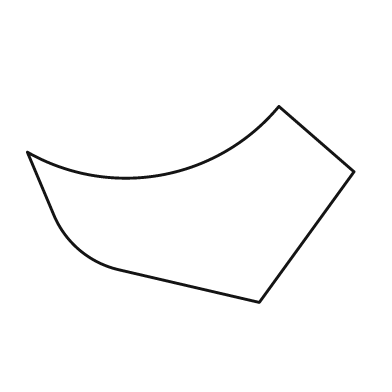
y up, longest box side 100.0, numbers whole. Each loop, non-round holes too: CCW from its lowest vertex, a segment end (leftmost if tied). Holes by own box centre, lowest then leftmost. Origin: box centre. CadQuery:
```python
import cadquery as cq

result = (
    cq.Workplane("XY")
    .moveTo(21.0, -30.0)
    .lineTo(50.0, 10.0)
    .lineTo(27.0, 30.0)
    .threePointArc((-9.0, 9.0), (-50.0, 16.0))
    .lineTo(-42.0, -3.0)
    .threePointArc((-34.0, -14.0), (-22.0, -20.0))
    .close()
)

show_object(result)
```